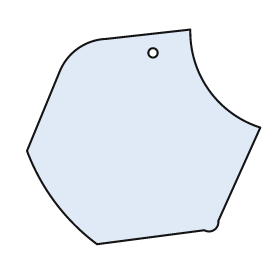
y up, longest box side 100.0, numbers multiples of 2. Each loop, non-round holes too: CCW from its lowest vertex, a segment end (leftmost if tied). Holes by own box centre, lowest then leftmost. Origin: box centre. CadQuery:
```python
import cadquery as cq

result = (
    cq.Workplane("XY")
    .moveTo(-20.0, -46.0)
    .lineTo(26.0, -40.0)
    .threePointArc((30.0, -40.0), (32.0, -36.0))
    .lineTo(50.0, 4.0)
    .threePointArc((28.0, 20.0), (20.0, 46.0))
    .lineTo(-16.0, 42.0)
    .threePointArc((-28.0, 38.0), (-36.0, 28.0))
    .lineTo(-50.0, -6.0)
    .threePointArc((-38.0, -28.0), (-20.0, -46.0))
    .close()
    .moveTo(4.0, 36.0)
    .circle(2.0)
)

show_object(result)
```